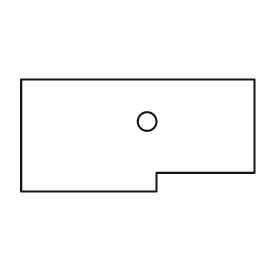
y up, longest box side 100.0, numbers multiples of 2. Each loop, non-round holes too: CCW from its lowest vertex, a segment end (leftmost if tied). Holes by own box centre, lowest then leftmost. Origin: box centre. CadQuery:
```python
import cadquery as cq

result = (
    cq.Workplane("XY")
    .moveTo(-50.0, -24.0)
    .lineTo(8.0, -24.0)
    .lineTo(8.0, -16.0)
    .lineTo(50.0, -16.0)
    .lineTo(50.0, 24.0)
    .lineTo(-50.0, 24.0)
    .close()
    .moveTo(4.0, 6.0)
    .circle(4.0)
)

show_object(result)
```